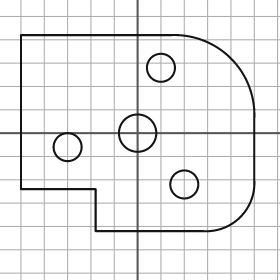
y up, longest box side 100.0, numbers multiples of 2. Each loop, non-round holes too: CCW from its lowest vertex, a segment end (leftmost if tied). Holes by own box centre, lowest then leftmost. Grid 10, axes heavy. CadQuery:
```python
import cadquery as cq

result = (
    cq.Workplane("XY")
    .moveTo(-18.0, -42.0)
    .lineTo(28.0, -42.0)
    .threePointArc((44.0, -36.0), (50.0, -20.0))
    .lineTo(50.0, 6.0)
    .threePointArc((40.0, 32.0), (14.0, 42.0))
    .lineTo(-50.0, 42.0)
    .lineTo(-50.0, -24.0)
    .lineTo(-18.0, -24.0)
    .close()
    .moveTo(20.0, -22.0)
    .circle(6.0)
    .moveTo(-30.0, -6.0)
    .circle(6.0)
    .moveTo(0.0, 0.0)
    .circle(8.0)
    .moveTo(10.0, 28.0)
    .circle(6.0)
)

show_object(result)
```